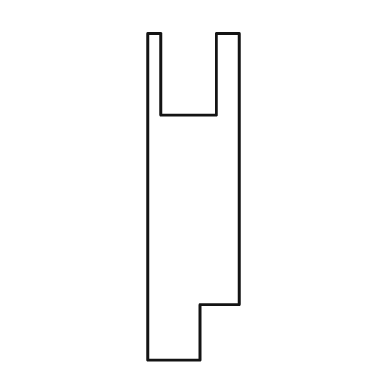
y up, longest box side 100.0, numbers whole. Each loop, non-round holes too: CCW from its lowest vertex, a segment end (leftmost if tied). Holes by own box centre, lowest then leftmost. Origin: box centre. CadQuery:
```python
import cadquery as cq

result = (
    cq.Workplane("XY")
    .moveTo(-14.0, -50.0)
    .lineTo(2.0, -50.0)
    .lineTo(2.0, -33.0)
    .lineTo(14.0, -33.0)
    .lineTo(14.0, 50.0)
    .lineTo(7.0, 50.0)
    .lineTo(7.0, 25.0)
    .lineTo(-10.0, 25.0)
    .lineTo(-10.0, 50.0)
    .lineTo(-14.0, 50.0)
    .close()
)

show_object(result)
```